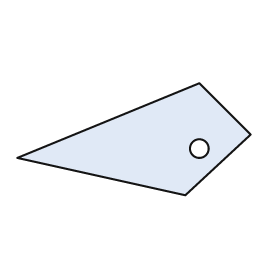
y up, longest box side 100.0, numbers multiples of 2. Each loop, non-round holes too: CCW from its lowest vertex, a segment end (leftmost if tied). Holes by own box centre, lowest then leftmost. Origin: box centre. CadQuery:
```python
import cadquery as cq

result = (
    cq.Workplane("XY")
    .moveTo(22.0, -24.0)
    .lineTo(50.0, 2.0)
    .lineTo(28.0, 24.0)
    .lineTo(-50.0, -8.0)
    .close()
    .moveTo(28.0, -4.0)
    .circle(4.0)
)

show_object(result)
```